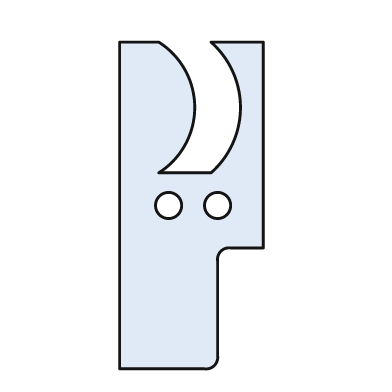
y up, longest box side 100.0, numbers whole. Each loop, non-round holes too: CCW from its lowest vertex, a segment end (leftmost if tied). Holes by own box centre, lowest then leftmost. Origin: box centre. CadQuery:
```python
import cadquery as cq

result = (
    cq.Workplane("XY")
    .moveTo(-22.0, -50.0)
    .lineTo(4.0, -50.0)
    .threePointArc((7.0, -49.0), (8.0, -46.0))
    .lineTo(8.0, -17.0)
    .threePointArc((9.0, -14.0), (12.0, -13.0))
    .lineTo(22.0, -13.0)
    .lineTo(22.0, 50.0)
    .lineTo(6.0, 50.0)
    .threePointArc((15.0, 30.0), (6.0, 10.0))
    .lineTo(-10.0, 10.0)
    .threePointArc((1.0, 30.0), (-10.0, 50.0))
    .lineTo(-22.0, 50.0)
    .close()
    .moveTo(-7.0, 0.0)
    .circle(4.0)
    .moveTo(8.0, 0.0)
    .circle(4.0)
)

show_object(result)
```